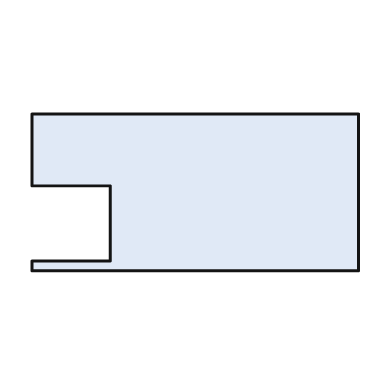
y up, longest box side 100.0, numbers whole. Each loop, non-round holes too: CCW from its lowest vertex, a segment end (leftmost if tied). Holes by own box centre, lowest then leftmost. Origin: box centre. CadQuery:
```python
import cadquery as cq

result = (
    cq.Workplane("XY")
    .moveTo(-50.0, -24.0)
    .lineTo(50.0, -24.0)
    .lineTo(50.0, 24.0)
    .lineTo(-50.0, 24.0)
    .lineTo(-50.0, 2.0)
    .lineTo(-26.0, 2.0)
    .lineTo(-26.0, -21.0)
    .lineTo(-50.0, -21.0)
    .close()
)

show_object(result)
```